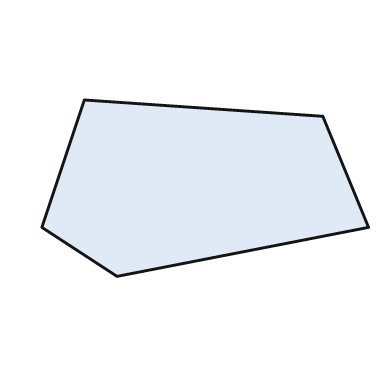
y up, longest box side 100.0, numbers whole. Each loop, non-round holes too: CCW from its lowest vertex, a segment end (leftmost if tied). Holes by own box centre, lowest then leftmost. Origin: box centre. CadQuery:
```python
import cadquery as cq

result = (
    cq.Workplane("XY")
    .moveTo(-27.0, -27.0)
    .lineTo(50.0, -12.0)
    .lineTo(36.0, 22.0)
    .lineTo(-37.0, 27.0)
    .lineTo(-50.0, -12.0)
    .close()
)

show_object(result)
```